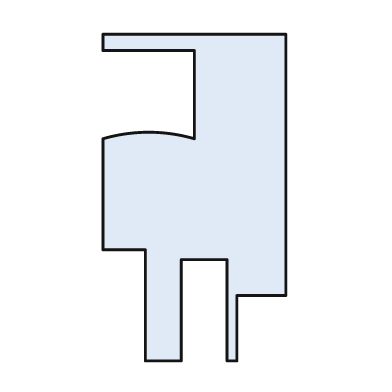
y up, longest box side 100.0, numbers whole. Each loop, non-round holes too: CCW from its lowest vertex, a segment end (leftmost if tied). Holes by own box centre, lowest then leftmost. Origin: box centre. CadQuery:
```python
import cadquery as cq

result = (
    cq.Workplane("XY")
    .moveTo(-15.0, -50.0)
    .lineTo(-4.0, -50.0)
    .lineTo(-4.0, -19.0)
    .lineTo(10.0, -19.0)
    .lineTo(10.0, -50.0)
    .lineTo(13.0, -50.0)
    .lineTo(13.0, -30.0)
    .lineTo(28.0, -30.0)
    .lineTo(28.0, 50.0)
    .lineTo(-28.0, 50.0)
    .lineTo(-28.0, 45.0)
    .lineTo(0.0, 45.0)
    .lineTo(0.0, 18.0)
    .threePointArc((-14.0, 20.0), (-28.0, 18.0))
    .lineTo(-28.0, -16.0)
    .lineTo(-15.0, -16.0)
    .close()
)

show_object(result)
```